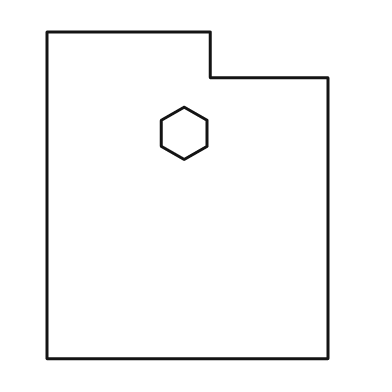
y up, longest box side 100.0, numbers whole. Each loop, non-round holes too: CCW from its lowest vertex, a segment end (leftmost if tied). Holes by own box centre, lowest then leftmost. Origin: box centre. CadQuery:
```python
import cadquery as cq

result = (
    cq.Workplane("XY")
    .moveTo(-43.0, -50.0)
    .lineTo(43.0, -50.0)
    .lineTo(43.0, 36.0)
    .lineTo(7.0, 36.0)
    .lineTo(7.0, 50.0)
    .lineTo(-43.0, 50.0)
    .close()
    .moveTo(-1.0, 11.0)
    .lineTo(6.0, 15.0)
    .lineTo(6.0, 23.0)
    .lineTo(-1.0, 27.0)
    .lineTo(-8.0, 23.0)
    .lineTo(-8.0, 15.0)
    .close()
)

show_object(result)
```